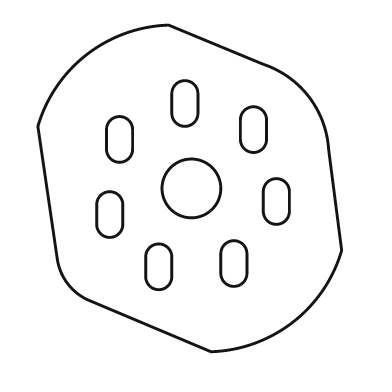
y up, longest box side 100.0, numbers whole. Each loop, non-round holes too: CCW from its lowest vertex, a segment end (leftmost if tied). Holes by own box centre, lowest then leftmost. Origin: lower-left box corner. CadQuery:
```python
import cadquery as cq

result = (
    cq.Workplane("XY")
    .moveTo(53.0, 0.0)
    .threePointArc((78.0, 9.0), (93.0, 31.0))
    .lineTo(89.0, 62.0)
    .threePointArc((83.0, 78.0), (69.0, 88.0))
    .lineTo(40.0, 100.0)
    .threePointArc((15.0, 91.0), (0.0, 69.0))
    .lineTo(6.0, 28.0)
    .threePointArc((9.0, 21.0), (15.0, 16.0))
    .close()
    .moveTo(33.0, 23.0)
    .threePointArc((37.0, 19.0), (41.0, 23.0))
    .lineTo(41.0, 29.0)
    .threePointArc((37.0, 33.0), (33.0, 29.0))
    .close()
    .moveTo(56.0, 24.0)
    .threePointArc((60.0, 20.0), (64.0, 24.0))
    .lineTo(64.0, 30.0)
    .threePointArc((60.0, 34.0), (56.0, 30.0))
    .close()
    .moveTo(18.0, 39.0)
    .threePointArc((22.0, 35.0), (26.0, 39.0))
    .lineTo(26.0, 45.0)
    .threePointArc((22.0, 49.0), (18.0, 45.0))
    .close()
    .moveTo(69.0, 43.0)
    .threePointArc((73.0, 39.0), (77.0, 43.0))
    .lineTo(77.0, 49.0)
    .threePointArc((73.0, 53.0), (69.0, 49.0))
    .close()
    .moveTo(47.0, 50.0)
    .circle(9.0)
    .moveTo(21.0, 62.0)
    .threePointArc((25.0, 58.0), (29.0, 62.0))
    .lineTo(29.0, 68.0)
    .threePointArc((25.0, 72.0), (21.0, 68.0))
    .close()
    .moveTo(62.0, 65.0)
    .threePointArc((66.0, 61.0), (70.0, 65.0))
    .lineTo(70.0, 71.0)
    .threePointArc((66.0, 75.0), (62.0, 71.0))
    .close()
    .moveTo(41.0, 73.0)
    .threePointArc((45.0, 69.0), (49.0, 73.0))
    .lineTo(49.0, 79.0)
    .threePointArc((45.0, 83.0), (41.0, 79.0))
    .close()
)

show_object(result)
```